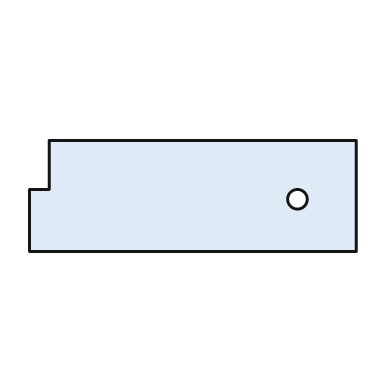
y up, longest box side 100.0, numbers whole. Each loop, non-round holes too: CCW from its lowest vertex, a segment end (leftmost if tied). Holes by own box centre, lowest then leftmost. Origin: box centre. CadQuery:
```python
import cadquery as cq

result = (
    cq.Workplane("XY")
    .moveTo(-50.0, -17.0)
    .lineTo(50.0, -17.0)
    .lineTo(50.0, 17.0)
    .lineTo(-44.0, 17.0)
    .lineTo(-44.0, 2.0)
    .lineTo(-50.0, 2.0)
    .close()
    .moveTo(32.0, -1.0)
    .circle(3.0)
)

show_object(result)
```